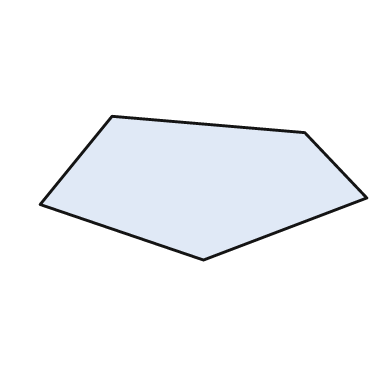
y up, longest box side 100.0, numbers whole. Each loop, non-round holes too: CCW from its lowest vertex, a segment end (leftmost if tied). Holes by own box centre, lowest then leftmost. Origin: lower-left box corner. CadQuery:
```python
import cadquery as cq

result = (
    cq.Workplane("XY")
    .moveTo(50.0, 0.0)
    .lineTo(100.0, 19.0)
    .lineTo(81.0, 39.0)
    .lineTo(22.0, 44.0)
    .lineTo(0.0, 17.0)
    .close()
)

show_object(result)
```